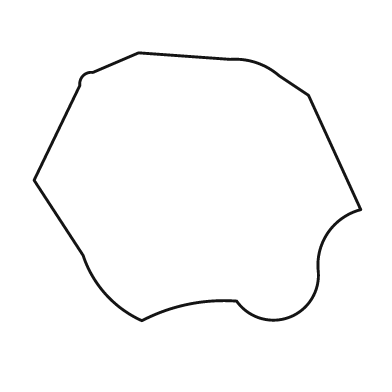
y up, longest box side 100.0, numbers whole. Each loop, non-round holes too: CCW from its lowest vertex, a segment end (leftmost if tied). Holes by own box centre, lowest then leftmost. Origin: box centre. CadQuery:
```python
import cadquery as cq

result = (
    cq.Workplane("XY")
    .moveTo(-17.0, -41.0)
    .threePointArc((-3.0, -36.0), (12.0, -35.0))
    .threePointArc((28.0, -40.0), (37.0, -26.0))
    .threePointArc((40.0, -14.0), (50.0, -7.0))
    .lineTo(34.0, 28.0)
    .lineTo(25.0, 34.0)
    .threePointArc((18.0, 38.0), (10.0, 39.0))
    .lineTo(-18.0, 41.0)
    .lineTo(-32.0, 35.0)
    .threePointArc((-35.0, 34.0), (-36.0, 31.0))
    .lineTo(-50.0, 2.0)
    .lineTo(-35.0, -21.0)
    .threePointArc((-28.0, -33.0), (-17.0, -41.0))
    .close()
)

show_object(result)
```